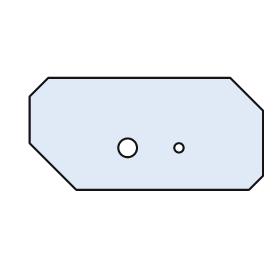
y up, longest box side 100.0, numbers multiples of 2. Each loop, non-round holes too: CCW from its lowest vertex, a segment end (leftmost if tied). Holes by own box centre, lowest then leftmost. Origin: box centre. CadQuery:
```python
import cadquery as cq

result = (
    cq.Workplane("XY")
    .moveTo(-30.0, -24.0)
    .lineTo(44.0, -24.0)
    .lineTo(50.0, -18.0)
    .lineTo(50.0, 10.0)
    .lineTo(36.0, 24.0)
    .lineTo(-42.0, 24.0)
    .lineTo(-50.0, 16.0)
    .lineTo(-50.0, -4.0)
    .close()
    .moveTo(-8.0, -6.0)
    .circle(4.0)
    .moveTo(14.0, -6.0)
    .circle(2.0)
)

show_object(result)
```